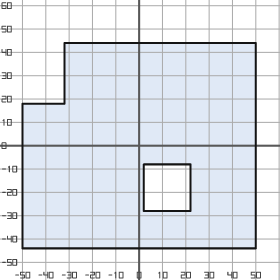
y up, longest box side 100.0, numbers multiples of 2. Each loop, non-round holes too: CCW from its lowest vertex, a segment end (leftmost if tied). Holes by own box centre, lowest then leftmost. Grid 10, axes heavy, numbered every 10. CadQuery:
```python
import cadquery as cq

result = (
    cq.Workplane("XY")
    .moveTo(-50.0, -44.0)
    .lineTo(50.0, -44.0)
    .lineTo(50.0, 44.0)
    .lineTo(-32.0, 44.0)
    .lineTo(-32.0, 18.0)
    .lineTo(-50.0, 18.0)
    .close()
    .moveTo(2.0, -28.0)
    .lineTo(22.0, -28.0)
    .lineTo(22.0, -8.0)
    .lineTo(2.0, -8.0)
    .close()
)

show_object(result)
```